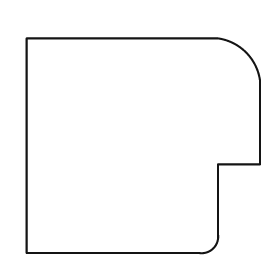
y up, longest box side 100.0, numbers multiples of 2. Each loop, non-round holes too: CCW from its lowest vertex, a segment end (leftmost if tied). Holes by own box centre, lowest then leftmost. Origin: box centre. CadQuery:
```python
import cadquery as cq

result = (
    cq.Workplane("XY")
    .moveTo(-50.0, -46.0)
    .lineTo(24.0, -46.0)
    .threePointArc((30.0, -44.0), (32.0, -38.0))
    .lineTo(32.0, -8.0)
    .lineTo(50.0, -8.0)
    .lineTo(50.0, 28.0)
    .threePointArc((44.0, 40.0), (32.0, 46.0))
    .lineTo(-50.0, 46.0)
    .close()
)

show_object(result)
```